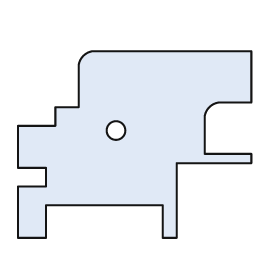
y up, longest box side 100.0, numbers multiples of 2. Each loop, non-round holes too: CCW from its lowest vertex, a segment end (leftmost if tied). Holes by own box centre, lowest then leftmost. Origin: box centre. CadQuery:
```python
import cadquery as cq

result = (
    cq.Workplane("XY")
    .moveTo(-50.0, -40.0)
    .lineTo(-38.0, -40.0)
    .lineTo(-38.0, -26.0)
    .lineTo(12.0, -26.0)
    .lineTo(12.0, -40.0)
    .lineTo(18.0, -40.0)
    .lineTo(18.0, -8.0)
    .lineTo(50.0, -8.0)
    .lineTo(50.0, -4.0)
    .lineTo(30.0, -4.0)
    .lineTo(30.0, 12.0)
    .threePointArc((32.0, 16.0), (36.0, 18.0))
    .lineTo(50.0, 18.0)
    .lineTo(50.0, 40.0)
    .lineTo(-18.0, 40.0)
    .threePointArc((-22.0, 38.0), (-24.0, 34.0))
    .lineTo(-24.0, 16.0)
    .lineTo(-34.0, 16.0)
    .lineTo(-34.0, 8.0)
    .lineTo(-50.0, 8.0)
    .lineTo(-50.0, -10.0)
    .lineTo(-38.0, -10.0)
    .lineTo(-38.0, -18.0)
    .lineTo(-50.0, -18.0)
    .close()
    .moveTo(-8.0, 6.0)
    .circle(4.0)
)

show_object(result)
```